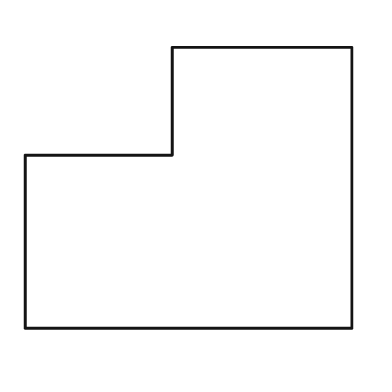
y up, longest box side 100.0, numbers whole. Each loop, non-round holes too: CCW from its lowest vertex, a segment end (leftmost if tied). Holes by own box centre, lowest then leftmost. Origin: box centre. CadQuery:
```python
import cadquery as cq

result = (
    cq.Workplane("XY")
    .moveTo(-50.0, -43.0)
    .lineTo(50.0, -43.0)
    .lineTo(50.0, 43.0)
    .lineTo(-5.0, 43.0)
    .lineTo(-5.0, 10.0)
    .lineTo(-50.0, 10.0)
    .close()
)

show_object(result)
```